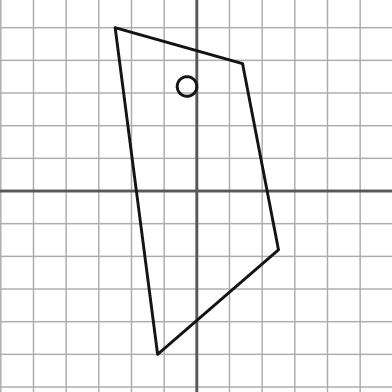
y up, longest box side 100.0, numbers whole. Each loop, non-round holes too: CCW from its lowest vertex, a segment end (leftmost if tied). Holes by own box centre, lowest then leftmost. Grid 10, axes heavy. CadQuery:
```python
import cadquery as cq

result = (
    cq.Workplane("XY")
    .moveTo(-12.0, -50.0)
    .lineTo(25.0, -18.0)
    .lineTo(14.0, 39.0)
    .lineTo(-25.0, 50.0)
    .close()
    .moveTo(-3.0, 32.0)
    .circle(3.0)
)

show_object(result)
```